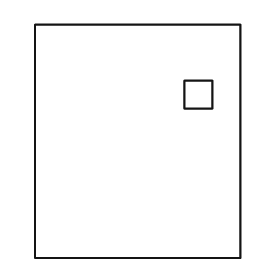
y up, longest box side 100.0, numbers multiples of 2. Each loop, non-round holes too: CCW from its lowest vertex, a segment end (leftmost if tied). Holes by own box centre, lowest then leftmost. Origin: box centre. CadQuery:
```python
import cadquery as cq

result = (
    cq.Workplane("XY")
    .moveTo(-44.0, -50.0)
    .lineTo(44.0, -50.0)
    .lineTo(44.0, 50.0)
    .lineTo(-44.0, 50.0)
    .close()
    .moveTo(20.0, 14.0)
    .lineTo(32.0, 14.0)
    .lineTo(32.0, 26.0)
    .lineTo(20.0, 26.0)
    .close()
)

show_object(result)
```